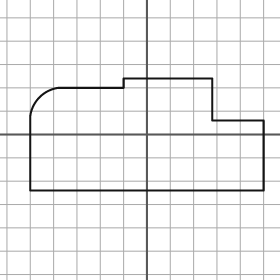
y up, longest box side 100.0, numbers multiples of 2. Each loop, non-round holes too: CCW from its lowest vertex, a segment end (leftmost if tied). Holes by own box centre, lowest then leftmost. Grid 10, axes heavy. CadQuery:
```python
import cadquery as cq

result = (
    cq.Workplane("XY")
    .moveTo(-50.0, -24.0)
    .lineTo(50.0, -24.0)
    .lineTo(50.0, 6.0)
    .lineTo(28.0, 6.0)
    .lineTo(28.0, 24.0)
    .lineTo(-10.0, 24.0)
    .lineTo(-10.0, 20.0)
    .lineTo(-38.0, 20.0)
    .threePointArc((-46.0, 16.0), (-50.0, 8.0))
    .close()
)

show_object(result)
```